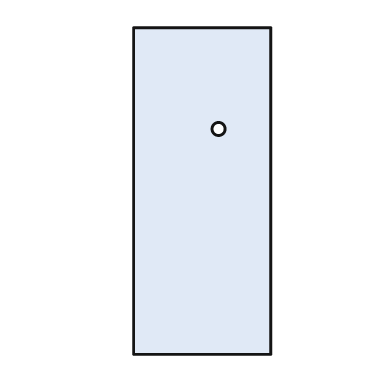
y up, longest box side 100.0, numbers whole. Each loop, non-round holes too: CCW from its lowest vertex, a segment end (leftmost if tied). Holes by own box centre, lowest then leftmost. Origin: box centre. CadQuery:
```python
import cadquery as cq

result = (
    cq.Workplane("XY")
    .moveTo(-21.0, -50.0)
    .lineTo(21.0, -50.0)
    .lineTo(21.0, 50.0)
    .lineTo(-21.0, 50.0)
    .close()
    .moveTo(5.0, 19.0)
    .circle(2.0)
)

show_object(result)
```